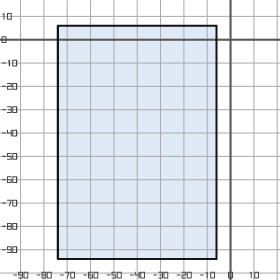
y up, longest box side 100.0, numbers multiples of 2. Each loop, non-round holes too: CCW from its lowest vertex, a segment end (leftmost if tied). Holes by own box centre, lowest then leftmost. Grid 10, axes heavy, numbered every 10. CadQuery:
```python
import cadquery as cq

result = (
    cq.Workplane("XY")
    .moveTo(-74.0, -94.0)
    .lineTo(-6.0, -94.0)
    .lineTo(-6.0, 6.0)
    .lineTo(-74.0, 6.0)
    .close()
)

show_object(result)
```